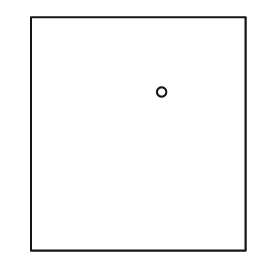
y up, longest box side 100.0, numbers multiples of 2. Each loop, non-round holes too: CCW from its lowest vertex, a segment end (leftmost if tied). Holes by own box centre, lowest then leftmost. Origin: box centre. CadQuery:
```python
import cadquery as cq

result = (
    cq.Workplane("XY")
    .moveTo(-46.0, -50.0)
    .lineTo(46.0, -50.0)
    .lineTo(46.0, 50.0)
    .lineTo(-46.0, 50.0)
    .close()
    .moveTo(10.0, 18.0)
    .circle(2.0)
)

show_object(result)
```